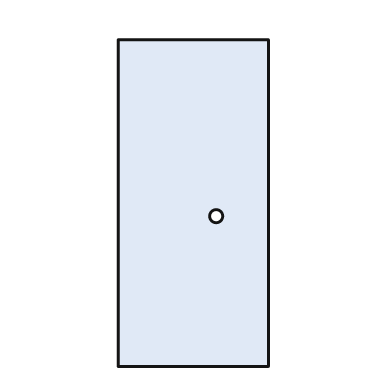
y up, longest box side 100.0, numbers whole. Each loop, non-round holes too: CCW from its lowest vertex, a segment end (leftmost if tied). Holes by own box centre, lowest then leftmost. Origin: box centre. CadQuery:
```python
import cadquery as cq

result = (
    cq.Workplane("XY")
    .moveTo(-23.0, -50.0)
    .lineTo(23.0, -50.0)
    .lineTo(23.0, 50.0)
    .lineTo(-23.0, 50.0)
    .close()
    .moveTo(7.0, -4.0)
    .circle(2.0)
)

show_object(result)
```